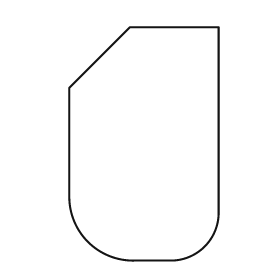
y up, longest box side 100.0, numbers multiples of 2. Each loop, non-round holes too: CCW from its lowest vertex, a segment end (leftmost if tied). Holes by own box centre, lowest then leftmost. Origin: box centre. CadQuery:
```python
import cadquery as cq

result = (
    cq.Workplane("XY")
    .moveTo(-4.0, -50.0)
    .lineTo(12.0, -50.0)
    .threePointArc((26.0, -44.0), (32.0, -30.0))
    .lineTo(32.0, 50.0)
    .lineTo(-6.0, 50.0)
    .lineTo(-32.0, 24.0)
    .lineTo(-32.0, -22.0)
    .threePointArc((-24.0, -42.0), (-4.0, -50.0))
    .close()
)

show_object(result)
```